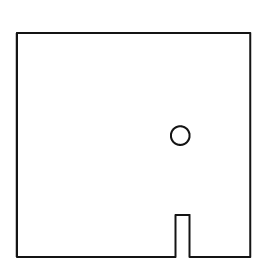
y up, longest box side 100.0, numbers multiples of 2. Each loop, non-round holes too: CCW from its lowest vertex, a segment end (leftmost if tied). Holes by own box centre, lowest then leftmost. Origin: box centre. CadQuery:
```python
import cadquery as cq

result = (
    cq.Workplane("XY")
    .moveTo(-50.0, -48.0)
    .lineTo(18.0, -48.0)
    .lineTo(18.0, -30.0)
    .lineTo(24.0, -30.0)
    .lineTo(24.0, -48.0)
    .lineTo(50.0, -48.0)
    .lineTo(50.0, 48.0)
    .lineTo(-50.0, 48.0)
    .close()
    .moveTo(20.0, 4.0)
    .circle(4.0)
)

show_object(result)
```